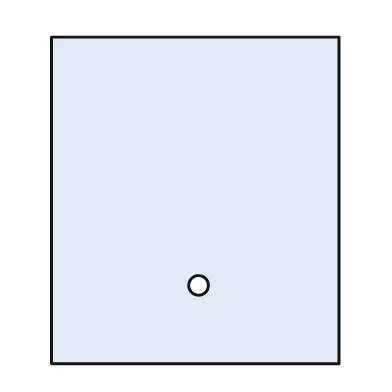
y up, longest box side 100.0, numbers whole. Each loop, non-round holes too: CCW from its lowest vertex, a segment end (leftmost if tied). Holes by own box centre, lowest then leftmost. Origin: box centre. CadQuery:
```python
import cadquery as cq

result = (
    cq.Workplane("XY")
    .moveTo(-44.0, -50.0)
    .lineTo(44.0, -50.0)
    .lineTo(44.0, 50.0)
    .lineTo(-44.0, 50.0)
    .close()
    .moveTo(1.0, -26.0)
    .circle(3.0)
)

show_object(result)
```